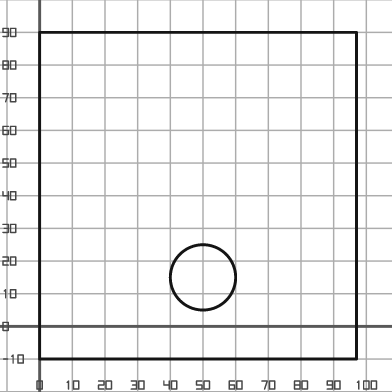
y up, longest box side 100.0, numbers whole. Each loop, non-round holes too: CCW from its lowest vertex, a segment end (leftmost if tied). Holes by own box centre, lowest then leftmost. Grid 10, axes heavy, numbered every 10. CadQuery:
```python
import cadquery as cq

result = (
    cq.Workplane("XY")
    .moveTo(0.0, -10.0)
    .lineTo(97.0, -10.0)
    .lineTo(97.0, 90.0)
    .lineTo(0.0, 90.0)
    .close()
    .moveTo(50.0, 15.0)
    .circle(10.0)
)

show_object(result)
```